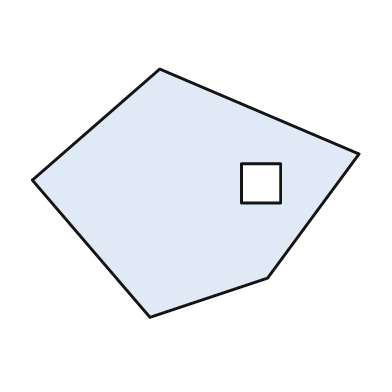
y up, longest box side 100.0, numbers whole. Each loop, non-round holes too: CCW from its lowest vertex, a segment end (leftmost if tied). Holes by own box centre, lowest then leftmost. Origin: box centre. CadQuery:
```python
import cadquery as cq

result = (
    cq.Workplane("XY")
    .moveTo(-14.0, -38.0)
    .lineTo(22.0, -26.0)
    .lineTo(50.0, 12.0)
    .lineTo(-11.0, 38.0)
    .lineTo(-50.0, 4.0)
    .close()
    .moveTo(14.0, -3.0)
    .lineTo(26.0, -3.0)
    .lineTo(26.0, 9.0)
    .lineTo(14.0, 9.0)
    .close()
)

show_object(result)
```